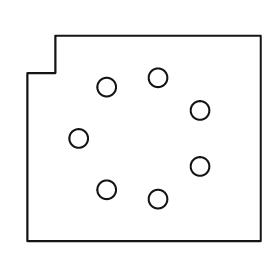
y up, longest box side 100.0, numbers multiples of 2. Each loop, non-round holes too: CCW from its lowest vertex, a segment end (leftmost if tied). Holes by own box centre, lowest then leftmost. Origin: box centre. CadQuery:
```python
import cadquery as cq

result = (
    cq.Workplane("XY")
    .moveTo(-50.0, -44.0)
    .lineTo(50.0, -44.0)
    .lineTo(50.0, 44.0)
    .lineTo(-38.0, 44.0)
    .lineTo(-38.0, 28.0)
    .lineTo(-50.0, 28.0)
    .close()
    .moveTo(6.0, -26.0)
    .circle(4.0)
    .moveTo(-16.0, -22.0)
    .circle(4.0)
    .moveTo(24.0, -12.0)
    .circle(4.0)
    .moveTo(-28.0, 0.0)
    .circle(4.0)
    .moveTo(24.0, 12.0)
    .circle(4.0)
    .moveTo(-16.0, 22.0)
    .circle(4.0)
    .moveTo(6.0, 26.0)
    .circle(4.0)
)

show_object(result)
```